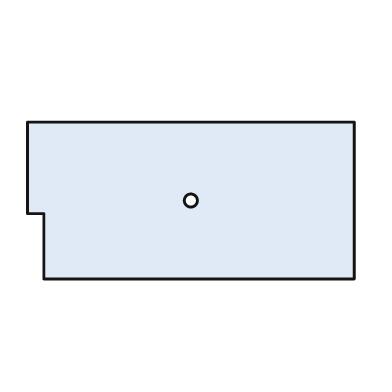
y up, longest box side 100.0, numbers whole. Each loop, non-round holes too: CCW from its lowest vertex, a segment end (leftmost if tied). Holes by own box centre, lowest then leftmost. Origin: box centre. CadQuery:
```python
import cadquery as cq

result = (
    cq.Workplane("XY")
    .moveTo(-45.0, -24.0)
    .lineTo(50.0, -24.0)
    .lineTo(50.0, 24.0)
    .lineTo(-50.0, 24.0)
    .lineTo(-50.0, -4.0)
    .lineTo(-45.0, -4.0)
    .close()
    .moveTo(0.0, 0.0)
    .circle(2.0)
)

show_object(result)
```